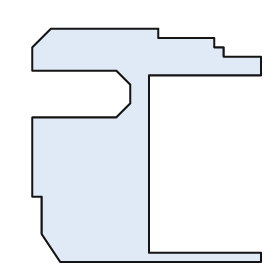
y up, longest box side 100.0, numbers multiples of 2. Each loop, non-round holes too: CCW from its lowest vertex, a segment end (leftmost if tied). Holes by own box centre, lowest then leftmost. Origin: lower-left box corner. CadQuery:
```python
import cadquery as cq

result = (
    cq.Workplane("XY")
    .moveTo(12.0, 0.0)
    .lineTo(98.0, 0.0)
    .lineTo(98.0, 4.0)
    .lineTo(50.0, 4.0)
    .lineTo(50.0, 80.0)
    .lineTo(98.0, 80.0)
    .lineTo(98.0, 88.0)
    .lineTo(82.0, 88.0)
    .lineTo(82.0, 92.0)
    .lineTo(78.0, 92.0)
    .lineTo(78.0, 96.0)
    .lineTo(54.0, 96.0)
    .lineTo(54.0, 100.0)
    .lineTo(8.0, 100.0)
    .lineTo(0.0, 92.0)
    .lineTo(0.0, 82.0)
    .lineTo(36.0, 82.0)
    .lineTo(42.0, 76.0)
    .lineTo(42.0, 68.0)
    .lineTo(36.0, 62.0)
    .lineTo(0.0, 62.0)
    .lineTo(0.0, 28.0)
    .lineTo(4.0, 28.0)
    .lineTo(4.0, 12.0)
    .close()
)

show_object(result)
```